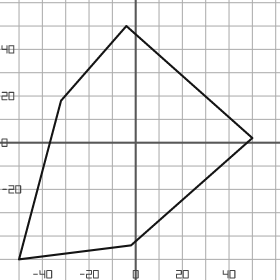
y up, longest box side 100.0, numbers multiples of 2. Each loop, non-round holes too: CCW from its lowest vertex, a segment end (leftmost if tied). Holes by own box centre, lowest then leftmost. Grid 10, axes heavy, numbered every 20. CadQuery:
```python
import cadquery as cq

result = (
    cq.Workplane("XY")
    .moveTo(-50.0, -50.0)
    .lineTo(-2.0, -44.0)
    .lineTo(50.0, 2.0)
    .lineTo(-4.0, 50.0)
    .lineTo(-32.0, 18.0)
    .close()
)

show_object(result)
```